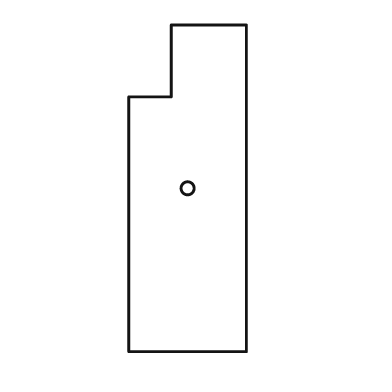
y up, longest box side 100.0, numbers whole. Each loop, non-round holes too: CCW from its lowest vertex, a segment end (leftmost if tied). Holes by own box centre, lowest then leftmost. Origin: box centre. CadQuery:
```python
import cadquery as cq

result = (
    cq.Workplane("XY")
    .moveTo(-18.0, -50.0)
    .lineTo(18.0, -50.0)
    .lineTo(18.0, 50.0)
    .lineTo(-5.0, 50.0)
    .lineTo(-5.0, 28.0)
    .lineTo(-18.0, 28.0)
    .close()
    .moveTo(0.0, 0.0)
    .circle(2.0)
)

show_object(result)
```